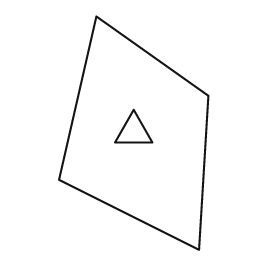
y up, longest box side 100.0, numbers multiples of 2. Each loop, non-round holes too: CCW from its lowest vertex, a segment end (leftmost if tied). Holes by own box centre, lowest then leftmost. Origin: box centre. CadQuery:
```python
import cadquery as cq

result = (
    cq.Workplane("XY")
    .moveTo(28.0, -50.0)
    .lineTo(32.0, 16.0)
    .lineTo(-16.0, 50.0)
    .lineTo(-32.0, -20.0)
    .close()
    .moveTo(-8.0, -4.0)
    .lineTo(8.0, -4.0)
    .lineTo(0.0, 10.0)
    .close()
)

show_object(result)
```